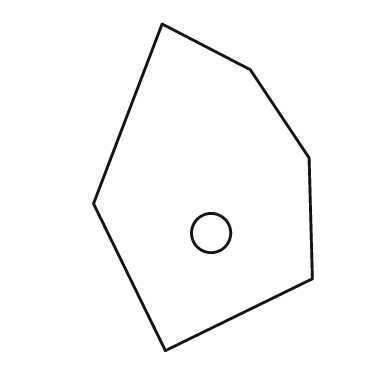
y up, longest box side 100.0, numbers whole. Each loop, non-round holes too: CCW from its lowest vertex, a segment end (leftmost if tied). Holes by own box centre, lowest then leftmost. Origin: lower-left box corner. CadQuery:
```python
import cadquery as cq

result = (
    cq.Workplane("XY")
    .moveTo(22.0, 0.0)
    .lineTo(67.0, 22.0)
    .lineTo(66.0, 59.0)
    .lineTo(48.0, 86.0)
    .lineTo(21.0, 100.0)
    .lineTo(0.0, 45.0)
    .close()
    .moveTo(36.0, 36.0)
    .circle(6.0)
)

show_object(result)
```